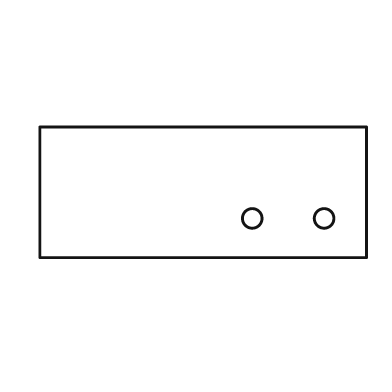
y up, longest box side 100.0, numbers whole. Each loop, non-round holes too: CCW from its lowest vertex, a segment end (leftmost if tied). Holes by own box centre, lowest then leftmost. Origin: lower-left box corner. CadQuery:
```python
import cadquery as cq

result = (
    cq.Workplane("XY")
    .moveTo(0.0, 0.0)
    .lineTo(100.0, 0.0)
    .lineTo(100.0, 40.0)
    .lineTo(0.0, 40.0)
    .close()
    .moveTo(65.0, 12.0)
    .circle(3.0)
    .moveTo(87.0, 12.0)
    .circle(3.0)
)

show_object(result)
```